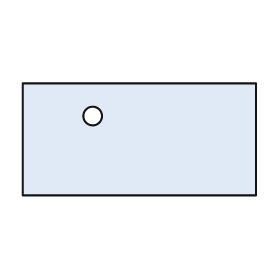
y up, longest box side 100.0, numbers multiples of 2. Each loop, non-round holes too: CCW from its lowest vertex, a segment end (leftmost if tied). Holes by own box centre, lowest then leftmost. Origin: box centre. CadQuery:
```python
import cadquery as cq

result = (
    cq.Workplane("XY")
    .moveTo(-50.0, -24.0)
    .lineTo(50.0, -24.0)
    .lineTo(50.0, 24.0)
    .lineTo(-50.0, 24.0)
    .close()
    .moveTo(-20.0, 10.0)
    .circle(4.0)
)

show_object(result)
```